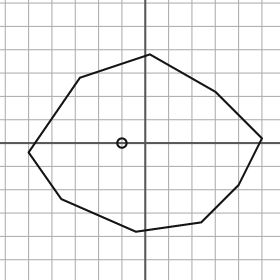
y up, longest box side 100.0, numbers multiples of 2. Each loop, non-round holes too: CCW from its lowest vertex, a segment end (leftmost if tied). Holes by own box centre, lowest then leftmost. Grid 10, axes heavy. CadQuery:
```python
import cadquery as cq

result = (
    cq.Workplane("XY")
    .moveTo(-4.0, -38.0)
    .lineTo(24.0, -34.0)
    .lineTo(40.0, -18.0)
    .lineTo(50.0, 2.0)
    .lineTo(30.0, 22.0)
    .lineTo(2.0, 38.0)
    .lineTo(-28.0, 28.0)
    .lineTo(-50.0, -4.0)
    .lineTo(-36.0, -24.0)
    .close()
    .moveTo(-10.0, 0.0)
    .circle(2.0)
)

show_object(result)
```